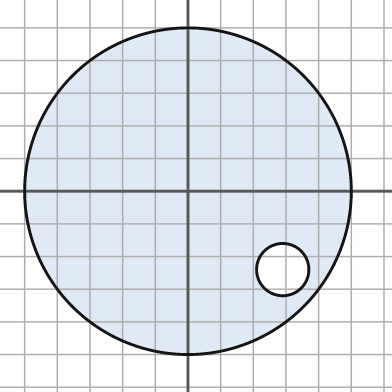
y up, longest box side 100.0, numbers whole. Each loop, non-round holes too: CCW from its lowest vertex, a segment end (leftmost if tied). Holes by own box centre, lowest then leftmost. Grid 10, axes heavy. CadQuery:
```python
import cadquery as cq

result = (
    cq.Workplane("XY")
    .moveTo(0.0, 0.0)
    .circle(50.0)
    .moveTo(29.0, -24.0)
    .circle(8.0)
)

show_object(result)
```